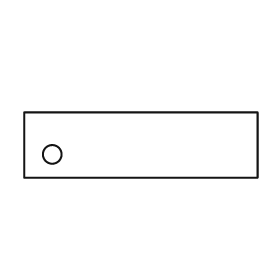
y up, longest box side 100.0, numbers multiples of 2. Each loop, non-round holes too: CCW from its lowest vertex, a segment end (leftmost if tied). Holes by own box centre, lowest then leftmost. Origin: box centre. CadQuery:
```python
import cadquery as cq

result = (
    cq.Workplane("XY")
    .moveTo(-50.0, -14.0)
    .lineTo(50.0, -14.0)
    .lineTo(50.0, 14.0)
    .lineTo(-50.0, 14.0)
    .close()
    .moveTo(-38.0, -4.0)
    .circle(4.0)
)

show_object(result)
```